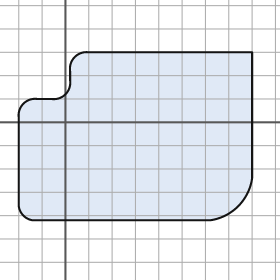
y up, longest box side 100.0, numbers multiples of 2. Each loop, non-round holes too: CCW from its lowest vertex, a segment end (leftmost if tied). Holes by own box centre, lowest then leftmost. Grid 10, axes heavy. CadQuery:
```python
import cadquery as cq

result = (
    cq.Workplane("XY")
    .moveTo(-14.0, -42.0)
    .lineTo(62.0, -42.0)
    .threePointArc((74.0, -36.0), (80.0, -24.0))
    .lineTo(80.0, 30.0)
    .lineTo(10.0, 30.0)
    .threePointArc((4.0, 28.0), (2.0, 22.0))
    .lineTo(2.0, 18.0)
    .threePointArc((0.0, 12.0), (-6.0, 10.0))
    .lineTo(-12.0, 10.0)
    .threePointArc((-18.0, 8.0), (-20.0, 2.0))
    .lineTo(-20.0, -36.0)
    .threePointArc((-18.0, -40.0), (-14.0, -42.0))
    .close()
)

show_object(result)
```